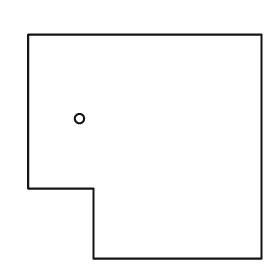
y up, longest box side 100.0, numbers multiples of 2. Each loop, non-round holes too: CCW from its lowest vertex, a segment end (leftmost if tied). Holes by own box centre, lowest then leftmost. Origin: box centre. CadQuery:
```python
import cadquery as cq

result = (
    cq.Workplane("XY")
    .moveTo(-22.0, -48.0)
    .lineTo(50.0, -48.0)
    .lineTo(50.0, 48.0)
    .lineTo(-50.0, 48.0)
    .lineTo(-50.0, -18.0)
    .lineTo(-22.0, -18.0)
    .close()
    .moveTo(-28.0, 12.0)
    .circle(2.0)
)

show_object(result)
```